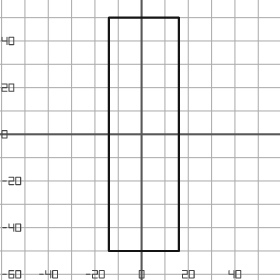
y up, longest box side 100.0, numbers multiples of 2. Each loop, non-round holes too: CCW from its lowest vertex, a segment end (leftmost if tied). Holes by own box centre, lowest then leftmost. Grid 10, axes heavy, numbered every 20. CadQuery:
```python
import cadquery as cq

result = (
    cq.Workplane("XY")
    .moveTo(-14.0, -50.0)
    .lineTo(16.0, -50.0)
    .lineTo(16.0, 50.0)
    .lineTo(-14.0, 50.0)
    .close()
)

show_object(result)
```